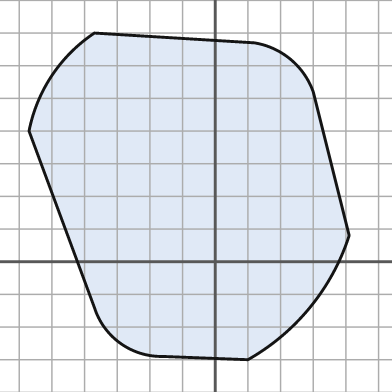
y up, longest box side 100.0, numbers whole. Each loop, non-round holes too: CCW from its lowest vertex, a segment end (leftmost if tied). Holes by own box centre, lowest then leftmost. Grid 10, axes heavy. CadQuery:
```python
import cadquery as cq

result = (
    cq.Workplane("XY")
    .moveTo(10.0, -30.0)
    .threePointArc((29.0, -14.0), (41.0, 8.0))
    .lineTo(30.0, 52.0)
    .threePointArc((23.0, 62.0), (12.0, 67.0))
    .lineTo(-37.0, 70.0)
    .threePointArc((-50.0, 57.0), (-57.0, 40.0))
    .lineTo(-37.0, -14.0)
    .threePointArc((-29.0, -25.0), (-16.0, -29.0))
    .close()
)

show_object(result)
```